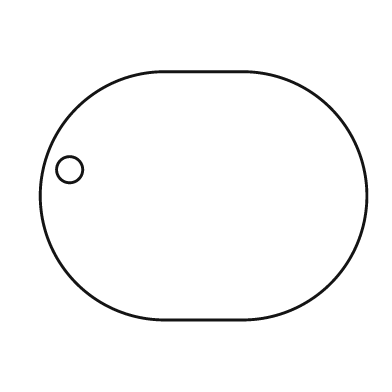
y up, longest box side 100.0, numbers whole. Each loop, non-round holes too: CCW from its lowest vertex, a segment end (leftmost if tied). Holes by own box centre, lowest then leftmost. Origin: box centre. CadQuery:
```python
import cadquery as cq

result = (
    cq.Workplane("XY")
    .moveTo(-12.0, -38.0)
    .lineTo(12.0, -38.0)
    .threePointArc((50.0, 0.0), (12.0, 38.0))
    .lineTo(-12.0, 38.0)
    .threePointArc((-50.0, 0.0), (-12.0, -38.0))
    .close()
    .moveTo(-41.0, 8.0)
    .circle(4.0)
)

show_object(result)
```